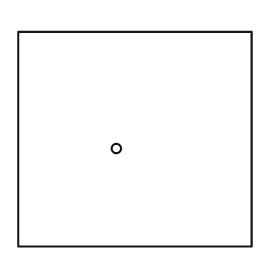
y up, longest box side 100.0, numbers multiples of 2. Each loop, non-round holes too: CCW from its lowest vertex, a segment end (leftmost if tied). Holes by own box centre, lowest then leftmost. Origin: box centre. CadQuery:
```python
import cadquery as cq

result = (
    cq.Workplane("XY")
    .moveTo(-50.0, -46.0)
    .lineTo(50.0, -46.0)
    .lineTo(50.0, 46.0)
    .lineTo(-50.0, 46.0)
    .close()
    .moveTo(-8.0, -4.0)
    .circle(2.0)
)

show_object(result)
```